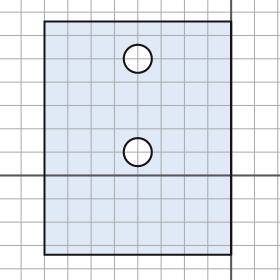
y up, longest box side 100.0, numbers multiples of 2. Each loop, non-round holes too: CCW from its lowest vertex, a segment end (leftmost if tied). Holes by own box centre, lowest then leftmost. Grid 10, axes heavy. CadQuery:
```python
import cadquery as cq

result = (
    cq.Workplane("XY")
    .moveTo(-80.0, -34.0)
    .lineTo(0.0, -34.0)
    .lineTo(0.0, 66.0)
    .lineTo(-80.0, 66.0)
    .close()
    .moveTo(-40.0, 10.0)
    .circle(6.0)
    .moveTo(-40.0, 50.0)
    .circle(6.0)
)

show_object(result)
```